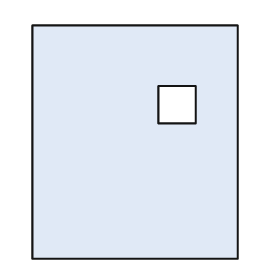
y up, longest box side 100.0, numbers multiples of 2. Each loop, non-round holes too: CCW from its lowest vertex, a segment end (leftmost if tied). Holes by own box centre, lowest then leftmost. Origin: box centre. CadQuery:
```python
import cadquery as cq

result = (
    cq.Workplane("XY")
    .moveTo(-44.0, -50.0)
    .lineTo(44.0, -50.0)
    .lineTo(44.0, 50.0)
    .lineTo(-44.0, 50.0)
    .close()
    .moveTo(10.0, 8.0)
    .lineTo(26.0, 8.0)
    .lineTo(26.0, 24.0)
    .lineTo(10.0, 24.0)
    .close()
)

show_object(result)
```